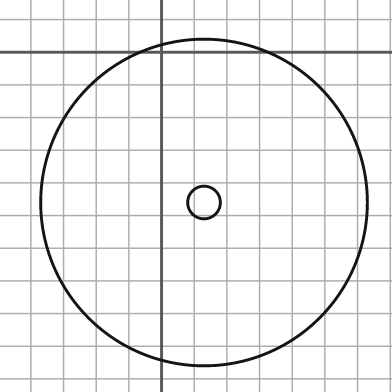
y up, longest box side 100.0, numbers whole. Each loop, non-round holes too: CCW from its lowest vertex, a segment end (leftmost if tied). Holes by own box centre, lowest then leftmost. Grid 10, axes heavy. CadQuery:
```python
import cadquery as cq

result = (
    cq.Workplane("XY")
    .moveTo(13.0, -46.0)
    .circle(50.0)
    .moveTo(13.0, -46.0)
    .circle(5.0)
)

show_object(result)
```